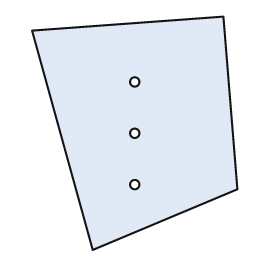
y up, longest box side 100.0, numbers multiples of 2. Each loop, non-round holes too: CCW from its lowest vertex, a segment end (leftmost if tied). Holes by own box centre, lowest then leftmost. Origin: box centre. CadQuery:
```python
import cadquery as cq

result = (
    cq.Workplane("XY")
    .moveTo(-18.0, -50.0)
    .lineTo(44.0, -24.0)
    .lineTo(38.0, 50.0)
    .lineTo(-44.0, 44.0)
    .close()
    .moveTo(0.0, -22.0)
    .circle(2.0)
    .moveTo(0.0, 0.0)
    .circle(2.0)
    .moveTo(0.0, 22.0)
    .circle(2.0)
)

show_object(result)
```